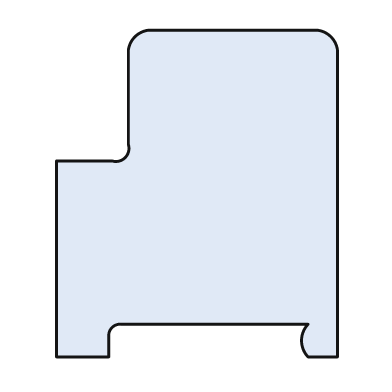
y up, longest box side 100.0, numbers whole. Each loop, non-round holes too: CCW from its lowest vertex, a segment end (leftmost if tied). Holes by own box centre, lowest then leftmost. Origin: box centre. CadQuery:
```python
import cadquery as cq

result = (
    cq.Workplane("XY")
    .moveTo(-43.0, -50.0)
    .lineTo(-27.0, -50.0)
    .lineTo(-27.0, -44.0)
    .threePointArc((-26.0, -41.0), (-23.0, -40.0))
    .lineTo(34.0, -40.0)
    .threePointArc((32.0, -45.0), (34.0, -50.0))
    .lineTo(43.0, -50.0)
    .lineTo(43.0, 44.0)
    .threePointArc((41.0, 48.0), (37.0, 50.0))
    .lineTo(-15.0, 50.0)
    .threePointArc((-19.0, 48.0), (-21.0, 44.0))
    .lineTo(-21.0, 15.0)
    .threePointArc((-22.0, 11.0), (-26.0, 10.0))
    .lineTo(-43.0, 10.0)
    .close()
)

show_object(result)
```